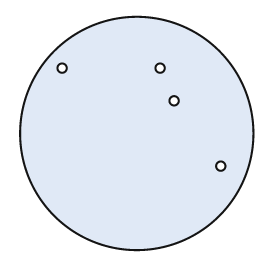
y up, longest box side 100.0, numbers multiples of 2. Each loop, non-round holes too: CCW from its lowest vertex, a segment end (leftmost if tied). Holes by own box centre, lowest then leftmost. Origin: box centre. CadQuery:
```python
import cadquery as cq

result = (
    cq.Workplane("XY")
    .moveTo(0.0, 0.0)
    .circle(50.0)
    .moveTo(36.0, -14.0)
    .circle(2.0)
    .moveTo(16.0, 14.0)
    .circle(2.0)
    .moveTo(-32.0, 28.0)
    .circle(2.0)
    .moveTo(10.0, 28.0)
    .circle(2.0)
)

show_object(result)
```